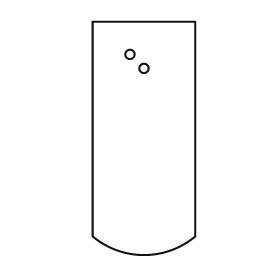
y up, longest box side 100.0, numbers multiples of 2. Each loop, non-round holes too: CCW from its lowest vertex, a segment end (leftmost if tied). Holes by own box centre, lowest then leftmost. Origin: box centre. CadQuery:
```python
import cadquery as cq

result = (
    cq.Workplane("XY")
    .moveTo(-22.0, -42.0)
    .threePointArc((0.0, -50.0), (22.0, -42.0))
    .lineTo(22.0, 50.0)
    .lineTo(-22.0, 50.0)
    .close()
    .moveTo(0.0, 30.0)
    .circle(2.0)
    .moveTo(-6.0, 36.0)
    .circle(2.0)
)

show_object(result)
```